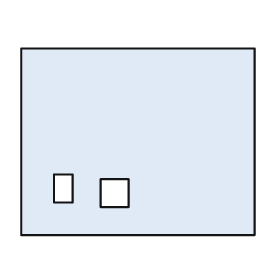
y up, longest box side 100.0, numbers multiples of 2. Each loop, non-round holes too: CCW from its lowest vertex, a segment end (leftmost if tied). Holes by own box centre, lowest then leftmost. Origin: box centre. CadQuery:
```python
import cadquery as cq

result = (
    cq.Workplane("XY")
    .moveTo(-50.0, -40.0)
    .lineTo(50.0, -40.0)
    .lineTo(50.0, 40.0)
    .lineTo(-50.0, 40.0)
    .close()
    .moveTo(-16.0, -28.0)
    .lineTo(-4.0, -28.0)
    .lineTo(-4.0, -16.0)
    .lineTo(-16.0, -16.0)
    .close()
    .moveTo(-36.0, -26.0)
    .lineTo(-28.0, -26.0)
    .lineTo(-28.0, -14.0)
    .lineTo(-36.0, -14.0)
    .close()
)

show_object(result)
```